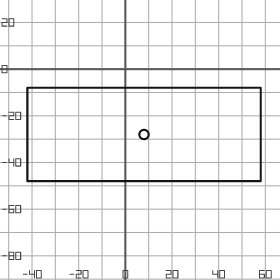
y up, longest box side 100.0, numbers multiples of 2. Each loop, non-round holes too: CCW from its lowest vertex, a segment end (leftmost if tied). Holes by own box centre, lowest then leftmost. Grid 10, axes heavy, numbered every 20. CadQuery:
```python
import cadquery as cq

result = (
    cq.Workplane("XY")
    .moveTo(-42.0, -48.0)
    .lineTo(58.0, -48.0)
    .lineTo(58.0, -8.0)
    .lineTo(-42.0, -8.0)
    .close()
    .moveTo(8.0, -28.0)
    .circle(2.0)
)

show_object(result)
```